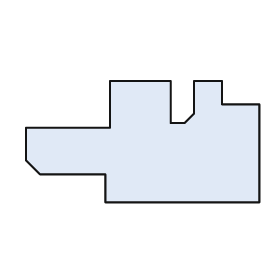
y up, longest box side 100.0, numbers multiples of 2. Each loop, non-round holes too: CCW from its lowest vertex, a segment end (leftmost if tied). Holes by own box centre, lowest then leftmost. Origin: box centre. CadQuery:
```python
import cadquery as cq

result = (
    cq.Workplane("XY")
    .moveTo(-16.0, -26.0)
    .lineTo(50.0, -26.0)
    .lineTo(50.0, 16.0)
    .lineTo(34.0, 16.0)
    .lineTo(34.0, 26.0)
    .lineTo(22.0, 26.0)
    .lineTo(22.0, 12.0)
    .lineTo(18.0, 8.0)
    .lineTo(12.0, 8.0)
    .lineTo(12.0, 26.0)
    .lineTo(-14.0, 26.0)
    .lineTo(-14.0, 6.0)
    .lineTo(-50.0, 6.0)
    .lineTo(-50.0, -8.0)
    .lineTo(-44.0, -14.0)
    .lineTo(-16.0, -14.0)
    .close()
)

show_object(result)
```